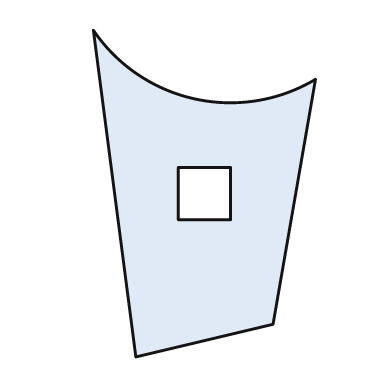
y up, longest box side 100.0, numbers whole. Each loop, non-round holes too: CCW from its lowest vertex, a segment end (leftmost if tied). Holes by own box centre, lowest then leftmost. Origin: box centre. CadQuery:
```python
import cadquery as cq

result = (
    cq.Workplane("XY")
    .moveTo(-21.0, -50.0)
    .lineTo(21.0, -40.0)
    .lineTo(34.0, 35.0)
    .threePointArc((-3.0, 29.0), (-34.0, 50.0))
    .close()
    .moveTo(-8.0, -8.0)
    .lineTo(8.0, -8.0)
    .lineTo(8.0, 8.0)
    .lineTo(-8.0, 8.0)
    .close()
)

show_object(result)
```